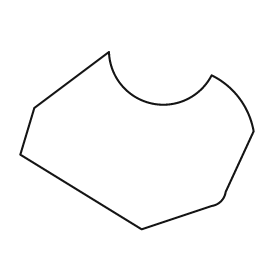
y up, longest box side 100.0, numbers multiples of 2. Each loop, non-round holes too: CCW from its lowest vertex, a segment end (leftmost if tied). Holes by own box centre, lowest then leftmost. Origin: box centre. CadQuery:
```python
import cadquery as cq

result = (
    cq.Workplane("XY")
    .moveTo(2.0, -38.0)
    .lineTo(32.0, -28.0)
    .threePointArc((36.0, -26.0), (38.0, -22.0))
    .lineTo(50.0, 4.0)
    .threePointArc((44.0, 18.0), (32.0, 28.0))
    .threePointArc((6.0, 16.0), (-12.0, 38.0))
    .lineTo(-44.0, 14.0)
    .lineTo(-50.0, -6.0)
    .close()
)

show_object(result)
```